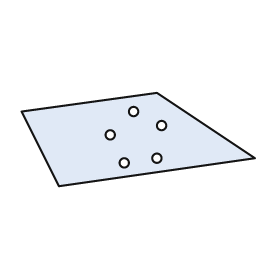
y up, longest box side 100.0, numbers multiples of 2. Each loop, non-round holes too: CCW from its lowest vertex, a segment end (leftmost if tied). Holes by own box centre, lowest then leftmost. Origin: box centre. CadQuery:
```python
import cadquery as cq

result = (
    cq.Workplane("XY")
    .moveTo(-34.0, -20.0)
    .lineTo(50.0, -8.0)
    .lineTo(8.0, 20.0)
    .lineTo(-50.0, 12.0)
    .close()
    .moveTo(-6.0, -10.0)
    .circle(2.0)
    .moveTo(8.0, -8.0)
    .circle(2.0)
    .moveTo(-12.0, 2.0)
    .circle(2.0)
    .moveTo(10.0, 6.0)
    .circle(2.0)
    .moveTo(-2.0, 12.0)
    .circle(2.0)
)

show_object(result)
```